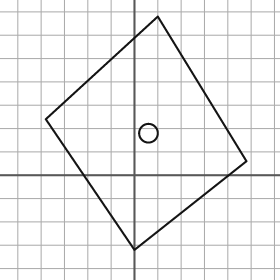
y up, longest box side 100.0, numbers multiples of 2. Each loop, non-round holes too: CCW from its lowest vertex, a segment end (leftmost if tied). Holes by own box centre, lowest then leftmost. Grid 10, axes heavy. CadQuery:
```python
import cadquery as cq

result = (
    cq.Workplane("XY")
    .moveTo(0.0, -32.0)
    .lineTo(48.0, 6.0)
    .lineTo(10.0, 68.0)
    .lineTo(-38.0, 24.0)
    .close()
    .moveTo(6.0, 18.0)
    .circle(4.0)
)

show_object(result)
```